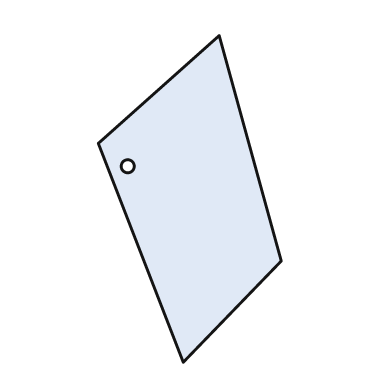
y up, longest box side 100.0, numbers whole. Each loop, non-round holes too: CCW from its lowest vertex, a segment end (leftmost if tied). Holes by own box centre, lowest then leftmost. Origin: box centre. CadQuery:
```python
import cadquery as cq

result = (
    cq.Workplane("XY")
    .moveTo(-2.0, -50.0)
    .lineTo(28.0, -19.0)
    .lineTo(9.0, 50.0)
    .lineTo(-28.0, 17.0)
    .close()
    .moveTo(-19.0, 10.0)
    .circle(2.0)
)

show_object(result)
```